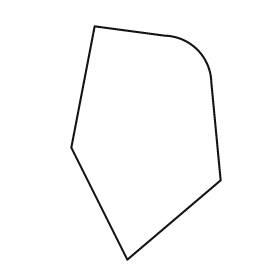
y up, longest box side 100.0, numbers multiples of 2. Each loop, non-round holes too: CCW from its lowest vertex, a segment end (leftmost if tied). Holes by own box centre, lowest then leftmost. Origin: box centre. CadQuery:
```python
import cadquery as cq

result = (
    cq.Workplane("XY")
    .moveTo(-8.0, -50.0)
    .lineTo(32.0, -16.0)
    .lineTo(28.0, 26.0)
    .threePointArc((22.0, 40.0), (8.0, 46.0))
    .lineTo(-22.0, 50.0)
    .lineTo(-32.0, -2.0)
    .close()
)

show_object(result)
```